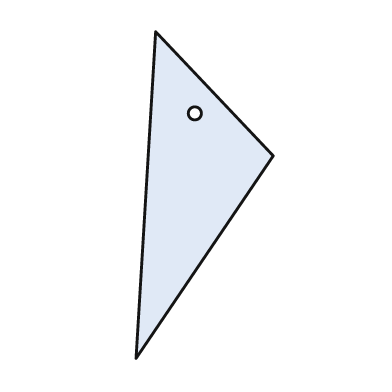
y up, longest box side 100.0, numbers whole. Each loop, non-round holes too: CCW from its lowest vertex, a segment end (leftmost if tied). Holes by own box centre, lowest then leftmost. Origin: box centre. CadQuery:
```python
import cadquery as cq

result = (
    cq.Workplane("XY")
    .moveTo(-21.0, -50.0)
    .lineTo(21.0, 12.0)
    .lineTo(-15.0, 50.0)
    .close()
    .moveTo(-3.0, 25.0)
    .circle(2.0)
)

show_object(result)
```